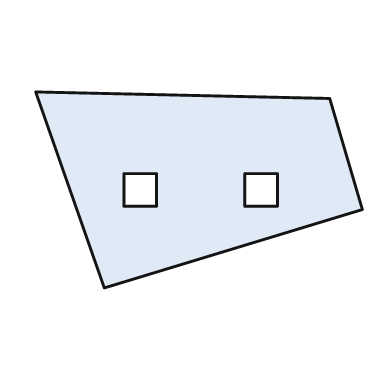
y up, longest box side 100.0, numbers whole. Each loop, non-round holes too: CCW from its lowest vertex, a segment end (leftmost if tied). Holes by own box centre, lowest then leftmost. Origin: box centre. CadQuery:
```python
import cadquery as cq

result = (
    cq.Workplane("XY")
    .moveTo(-29.0, -30.0)
    .lineTo(50.0, -6.0)
    .lineTo(40.0, 28.0)
    .lineTo(-50.0, 30.0)
    .close()
    .moveTo(-23.0, -5.0)
    .lineTo(-13.0, -5.0)
    .lineTo(-13.0, 5.0)
    .lineTo(-23.0, 5.0)
    .close()
    .moveTo(14.0, -5.0)
    .lineTo(24.0, -5.0)
    .lineTo(24.0, 5.0)
    .lineTo(14.0, 5.0)
    .close()
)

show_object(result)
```